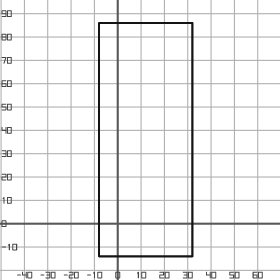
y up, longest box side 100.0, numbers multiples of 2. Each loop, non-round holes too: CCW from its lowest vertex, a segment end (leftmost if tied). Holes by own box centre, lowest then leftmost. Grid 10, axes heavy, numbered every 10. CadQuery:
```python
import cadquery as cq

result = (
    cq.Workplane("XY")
    .moveTo(-8.0, -14.0)
    .lineTo(32.0, -14.0)
    .lineTo(32.0, 86.0)
    .lineTo(-8.0, 86.0)
    .close()
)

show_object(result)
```